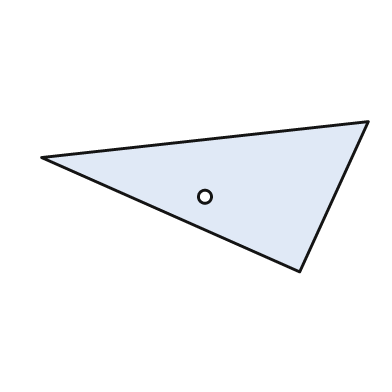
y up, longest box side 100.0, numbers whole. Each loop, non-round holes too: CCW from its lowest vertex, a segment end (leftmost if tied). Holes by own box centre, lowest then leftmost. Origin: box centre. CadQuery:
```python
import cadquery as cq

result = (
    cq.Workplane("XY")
    .moveTo(29.0, -23.0)
    .lineTo(50.0, 23.0)
    .lineTo(-50.0, 12.0)
    .close()
    .moveTo(0.0, 0.0)
    .circle(2.0)
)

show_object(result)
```